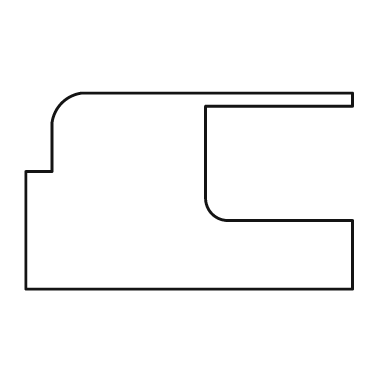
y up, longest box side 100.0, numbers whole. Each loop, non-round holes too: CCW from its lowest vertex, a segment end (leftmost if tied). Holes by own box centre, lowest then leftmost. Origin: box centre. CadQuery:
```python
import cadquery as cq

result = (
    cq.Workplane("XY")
    .moveTo(-50.0, -30.0)
    .lineTo(50.0, -30.0)
    .lineTo(50.0, -9.0)
    .lineTo(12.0, -9.0)
    .threePointArc((7.0, -7.0), (5.0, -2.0))
    .lineTo(5.0, 26.0)
    .lineTo(50.0, 26.0)
    .lineTo(50.0, 30.0)
    .lineTo(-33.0, 30.0)
    .threePointArc((-39.0, 27.0), (-42.0, 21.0))
    .lineTo(-42.0, 6.0)
    .lineTo(-50.0, 6.0)
    .close()
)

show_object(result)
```